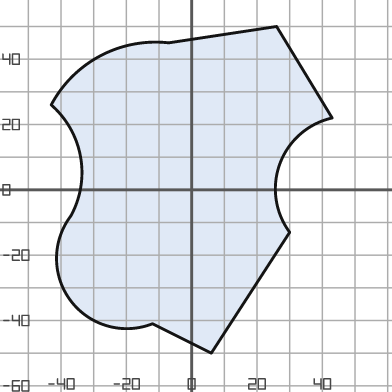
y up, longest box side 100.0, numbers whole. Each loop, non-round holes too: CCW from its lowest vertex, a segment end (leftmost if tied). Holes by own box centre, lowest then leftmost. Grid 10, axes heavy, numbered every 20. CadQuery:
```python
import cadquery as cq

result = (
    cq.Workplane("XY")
    .moveTo(6.0, -50.0)
    .lineTo(30.0, -13.0)
    .threePointArc((27.0, 8.0), (43.0, 22.0))
    .lineTo(26.0, 50.0)
    .lineTo(-7.0, 45.0)
    .threePointArc((-28.0, 41.0), (-43.0, 26.0))
    .threePointArc((-34.0, 10.0), (-37.0, -8.0))
    .threePointArc((-37.0, -34.0), (-12.0, -41.0))
    .close()
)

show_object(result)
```